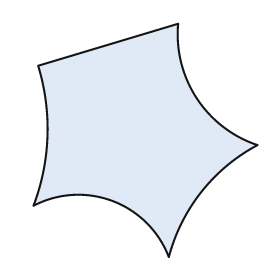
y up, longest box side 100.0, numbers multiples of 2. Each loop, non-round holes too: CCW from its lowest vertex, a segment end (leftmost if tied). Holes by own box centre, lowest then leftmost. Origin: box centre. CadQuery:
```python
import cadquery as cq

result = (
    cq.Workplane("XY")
    .moveTo(10.0, -50.0)
    .threePointArc((24.0, -22.0), (48.0, -2.0))
    .threePointArc((22.0, 18.0), (14.0, 50.0))
    .lineTo(-46.0, 32.0)
    .threePointArc((-42.0, 2.0), (-48.0, -28.0))
    .threePointArc((-14.0, -26.0), (10.0, -50.0))
    .close()
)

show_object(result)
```